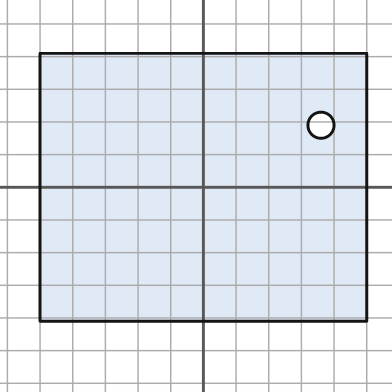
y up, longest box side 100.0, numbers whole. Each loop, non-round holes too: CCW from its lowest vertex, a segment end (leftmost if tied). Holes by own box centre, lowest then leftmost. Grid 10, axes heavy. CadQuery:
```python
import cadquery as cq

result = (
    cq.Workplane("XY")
    .moveTo(-50.0, -41.0)
    .lineTo(50.0, -41.0)
    .lineTo(50.0, 41.0)
    .lineTo(-50.0, 41.0)
    .close()
    .moveTo(36.0, 19.0)
    .circle(4.0)
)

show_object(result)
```